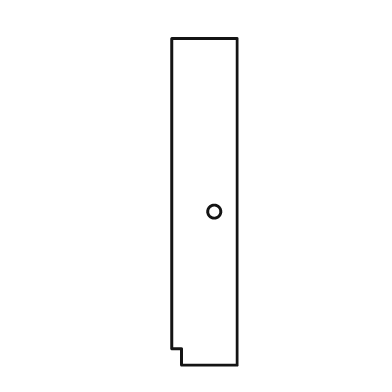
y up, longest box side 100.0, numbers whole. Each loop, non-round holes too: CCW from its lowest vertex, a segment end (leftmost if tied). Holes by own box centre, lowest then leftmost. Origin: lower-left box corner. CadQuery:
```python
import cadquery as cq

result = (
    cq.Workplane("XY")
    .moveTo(3.0, 0.0)
    .lineTo(20.0, 0.0)
    .lineTo(20.0, 100.0)
    .lineTo(0.0, 100.0)
    .lineTo(0.0, 5.0)
    .lineTo(3.0, 5.0)
    .close()
    .moveTo(13.0, 47.0)
    .circle(2.0)
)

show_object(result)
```